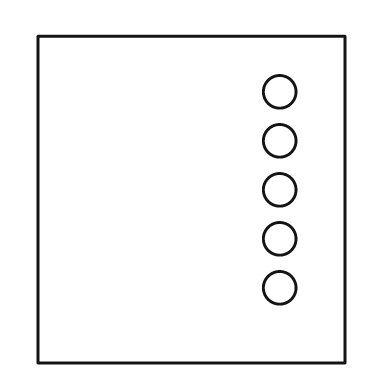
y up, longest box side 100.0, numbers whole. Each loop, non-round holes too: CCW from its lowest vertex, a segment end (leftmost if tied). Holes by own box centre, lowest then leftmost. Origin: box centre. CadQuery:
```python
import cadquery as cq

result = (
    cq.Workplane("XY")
    .moveTo(-47.0, -50.0)
    .lineTo(47.0, -50.0)
    .lineTo(47.0, 50.0)
    .lineTo(-47.0, 50.0)
    .close()
    .moveTo(27.0, -27.0)
    .circle(5.0)
    .moveTo(27.0, -12.0)
    .circle(5.0)
    .moveTo(27.0, 3.0)
    .circle(5.0)
    .moveTo(27.0, 18.0)
    .circle(5.0)
    .moveTo(27.0, 33.0)
    .circle(5.0)
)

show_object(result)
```